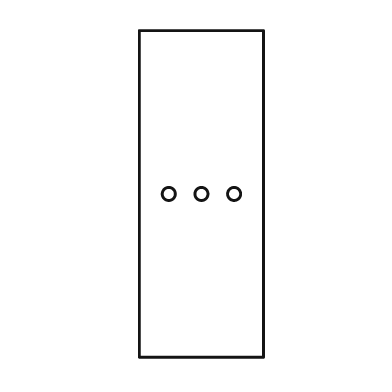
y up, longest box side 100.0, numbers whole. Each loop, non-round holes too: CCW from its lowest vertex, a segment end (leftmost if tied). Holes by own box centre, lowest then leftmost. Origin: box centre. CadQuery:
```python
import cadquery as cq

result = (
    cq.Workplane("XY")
    .moveTo(-19.0, -50.0)
    .lineTo(19.0, -50.0)
    .lineTo(19.0, 50.0)
    .lineTo(-19.0, 50.0)
    .close()
    .moveTo(-10.0, 0.0)
    .circle(2.0)
    .moveTo(0.0, 0.0)
    .circle(2.0)
    .moveTo(10.0, 0.0)
    .circle(2.0)
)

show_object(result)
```